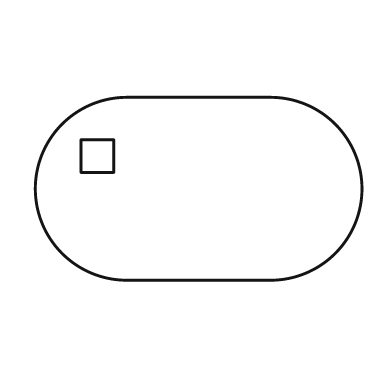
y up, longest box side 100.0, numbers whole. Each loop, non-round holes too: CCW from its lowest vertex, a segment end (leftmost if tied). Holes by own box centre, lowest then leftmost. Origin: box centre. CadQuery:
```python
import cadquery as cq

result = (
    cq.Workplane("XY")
    .moveTo(-22.0, -28.0)
    .lineTo(22.0, -28.0)
    .threePointArc((50.0, 0.0), (22.0, 28.0))
    .lineTo(-22.0, 28.0)
    .threePointArc((-50.0, 0.0), (-22.0, -28.0))
    .close()
    .moveTo(-36.0, 5.0)
    .lineTo(-26.0, 5.0)
    .lineTo(-26.0, 15.0)
    .lineTo(-36.0, 15.0)
    .close()
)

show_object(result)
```